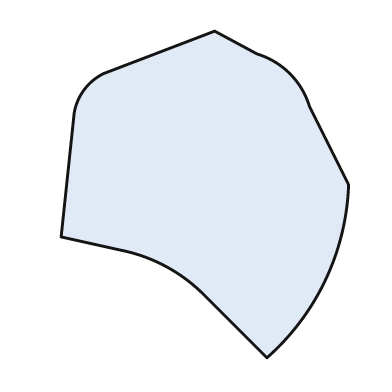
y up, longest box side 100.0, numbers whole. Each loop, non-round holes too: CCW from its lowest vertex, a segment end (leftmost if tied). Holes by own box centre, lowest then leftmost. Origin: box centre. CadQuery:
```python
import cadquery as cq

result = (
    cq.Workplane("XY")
    .moveTo(19.0, -50.0)
    .threePointArc((37.0, -26.0), (44.0, 3.0))
    .lineTo(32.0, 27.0)
    .threePointArc((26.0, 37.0), (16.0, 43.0))
    .lineTo(3.0, 50.0)
    .lineTo(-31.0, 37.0)
    .threePointArc((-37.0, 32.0), (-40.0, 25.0))
    .lineTo(-44.0, -13.0)
    .lineTo(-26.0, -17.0)
    .threePointArc((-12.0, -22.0), (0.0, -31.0))
    .close()
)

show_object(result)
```